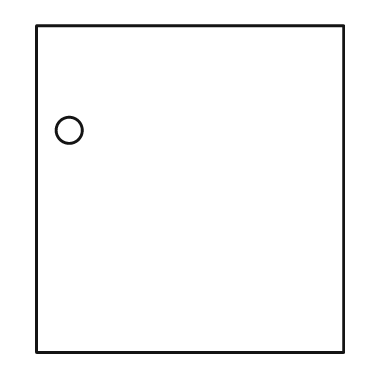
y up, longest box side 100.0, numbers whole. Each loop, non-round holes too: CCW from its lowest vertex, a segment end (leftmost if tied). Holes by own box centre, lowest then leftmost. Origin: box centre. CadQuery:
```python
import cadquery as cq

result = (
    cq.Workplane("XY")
    .moveTo(-47.0, -50.0)
    .lineTo(47.0, -50.0)
    .lineTo(47.0, 50.0)
    .lineTo(-47.0, 50.0)
    .close()
    .moveTo(-37.0, 18.0)
    .circle(4.0)
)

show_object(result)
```